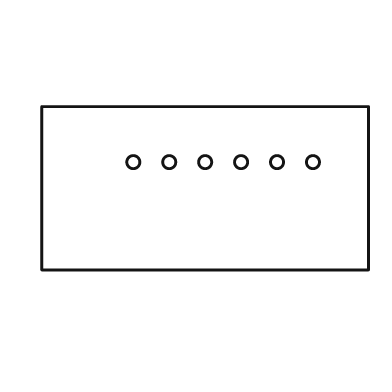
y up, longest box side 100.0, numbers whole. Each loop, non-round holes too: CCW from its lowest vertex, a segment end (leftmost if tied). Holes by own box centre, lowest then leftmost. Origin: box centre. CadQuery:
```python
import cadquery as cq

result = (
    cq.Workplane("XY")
    .moveTo(-50.0, -25.0)
    .lineTo(50.0, -25.0)
    .lineTo(50.0, 25.0)
    .lineTo(-50.0, 25.0)
    .close()
    .moveTo(-22.0, 8.0)
    .circle(2.0)
    .moveTo(-11.0, 8.0)
    .circle(2.0)
    .moveTo(0.0, 8.0)
    .circle(2.0)
    .moveTo(11.0, 8.0)
    .circle(2.0)
    .moveTo(22.0, 8.0)
    .circle(2.0)
    .moveTo(33.0, 8.0)
    .circle(2.0)
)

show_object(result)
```